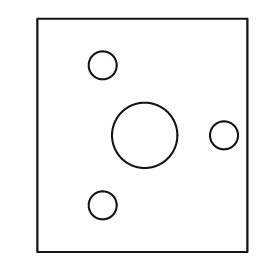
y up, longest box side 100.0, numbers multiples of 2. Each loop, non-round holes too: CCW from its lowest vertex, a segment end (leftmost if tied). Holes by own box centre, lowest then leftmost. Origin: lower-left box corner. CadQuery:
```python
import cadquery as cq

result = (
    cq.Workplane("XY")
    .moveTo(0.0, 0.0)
    .lineTo(90.0, 0.0)
    .lineTo(90.0, 100.0)
    .lineTo(0.0, 100.0)
    .close()
    .moveTo(28.0, 20.0)
    .circle(6.0)
    .moveTo(46.0, 50.0)
    .circle(14.0)
    .moveTo(80.0, 50.0)
    .circle(6.0)
    .moveTo(28.0, 80.0)
    .circle(6.0)
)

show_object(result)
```